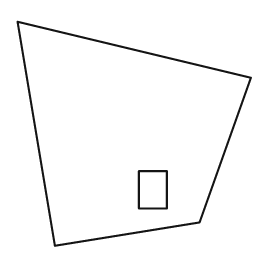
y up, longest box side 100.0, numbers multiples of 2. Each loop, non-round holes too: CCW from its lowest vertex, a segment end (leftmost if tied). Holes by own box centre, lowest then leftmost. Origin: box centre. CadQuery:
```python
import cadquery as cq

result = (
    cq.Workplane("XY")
    .moveTo(-34.0, -48.0)
    .lineTo(28.0, -38.0)
    .lineTo(50.0, 24.0)
    .lineTo(-50.0, 48.0)
    .close()
    .moveTo(2.0, -32.0)
    .lineTo(14.0, -32.0)
    .lineTo(14.0, -16.0)
    .lineTo(2.0, -16.0)
    .close()
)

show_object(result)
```